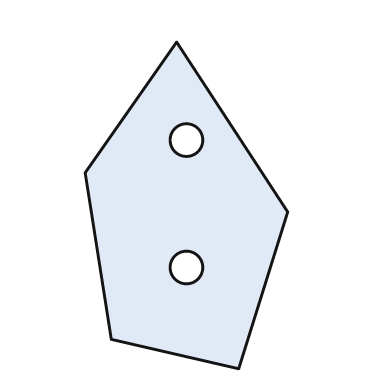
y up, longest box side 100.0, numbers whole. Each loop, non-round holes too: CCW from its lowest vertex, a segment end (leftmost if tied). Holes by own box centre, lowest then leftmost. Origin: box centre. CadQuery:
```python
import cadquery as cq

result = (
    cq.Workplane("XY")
    .moveTo(16.0, -50.0)
    .lineTo(31.0, -2.0)
    .lineTo(-3.0, 50.0)
    .lineTo(-31.0, 10.0)
    .lineTo(-23.0, -41.0)
    .close()
    .moveTo(0.0, -19.0)
    .circle(5.0)
    .moveTo(0.0, 20.0)
    .circle(5.0)
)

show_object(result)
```